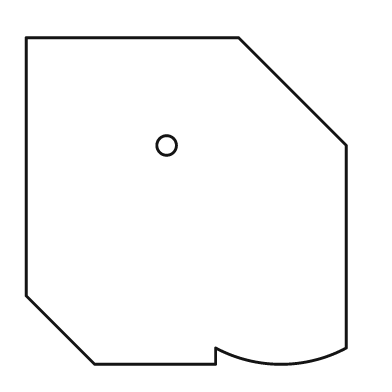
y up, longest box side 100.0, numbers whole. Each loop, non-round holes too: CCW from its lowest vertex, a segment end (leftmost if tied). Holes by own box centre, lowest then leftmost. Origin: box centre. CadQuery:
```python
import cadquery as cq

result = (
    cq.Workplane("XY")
    .moveTo(-28.0, -50.0)
    .lineTo(9.0, -50.0)
    .lineTo(9.0, -45.0)
    .threePointArc((29.0, -50.0), (49.0, -45.0))
    .lineTo(49.0, 17.0)
    .lineTo(16.0, 50.0)
    .lineTo(-49.0, 50.0)
    .lineTo(-49.0, -29.0)
    .close()
    .moveTo(-6.0, 17.0)
    .circle(3.0)
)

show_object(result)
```